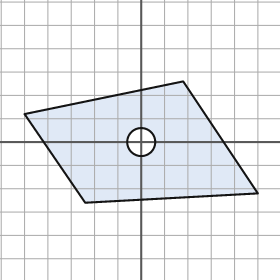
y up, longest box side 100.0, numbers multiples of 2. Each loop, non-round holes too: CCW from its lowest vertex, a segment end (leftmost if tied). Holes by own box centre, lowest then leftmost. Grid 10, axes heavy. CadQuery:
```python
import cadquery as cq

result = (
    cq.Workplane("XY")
    .moveTo(-24.0, -26.0)
    .lineTo(50.0, -22.0)
    .lineTo(18.0, 26.0)
    .lineTo(-50.0, 12.0)
    .close()
    .moveTo(0.0, 0.0)
    .circle(6.0)
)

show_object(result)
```